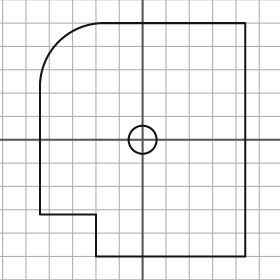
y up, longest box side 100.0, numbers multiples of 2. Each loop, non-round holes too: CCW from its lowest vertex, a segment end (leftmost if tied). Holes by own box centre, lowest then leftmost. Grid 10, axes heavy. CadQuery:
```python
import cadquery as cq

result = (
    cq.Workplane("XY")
    .moveTo(-20.0, -50.0)
    .lineTo(44.0, -50.0)
    .lineTo(44.0, 50.0)
    .lineTo(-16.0, 50.0)
    .threePointArc((-36.0, 42.0), (-44.0, 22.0))
    .lineTo(-44.0, -32.0)
    .lineTo(-20.0, -32.0)
    .close()
    .moveTo(0.0, 0.0)
    .circle(6.0)
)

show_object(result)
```